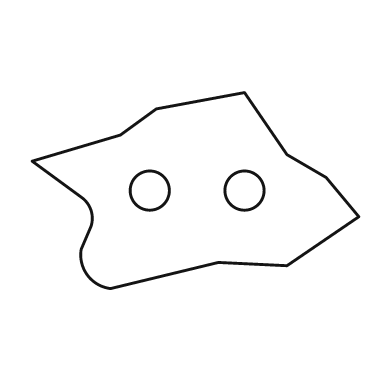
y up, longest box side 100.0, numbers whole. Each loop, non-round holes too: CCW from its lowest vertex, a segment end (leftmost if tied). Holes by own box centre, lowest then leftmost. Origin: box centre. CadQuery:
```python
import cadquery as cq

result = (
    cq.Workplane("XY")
    .moveTo(-26.0, -30.0)
    .lineTo(7.0, -22.0)
    .lineTo(28.0, -23.0)
    .lineTo(50.0, -8.0)
    .lineTo(40.0, 4.0)
    .lineTo(28.0, 11.0)
    .lineTo(15.0, 30.0)
    .lineTo(-12.0, 25.0)
    .lineTo(-23.0, 17.0)
    .lineTo(-50.0, 9.0)
    .lineTo(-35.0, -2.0)
    .threePointArc((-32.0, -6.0), (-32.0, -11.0))
    .lineTo(-35.0, -18.0)
    .threePointArc((-33.0, -26.0), (-26.0, -30.0))
    .close()
    .moveTo(-14.0, 0.0)
    .circle(6.0)
    .moveTo(15.0, 0.0)
    .circle(6.0)
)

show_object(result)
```